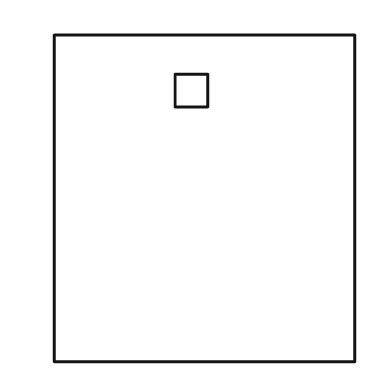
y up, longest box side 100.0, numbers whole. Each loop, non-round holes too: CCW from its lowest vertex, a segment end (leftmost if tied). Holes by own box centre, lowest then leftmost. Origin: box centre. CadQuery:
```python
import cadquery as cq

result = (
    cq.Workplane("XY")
    .moveTo(-46.0, -50.0)
    .lineTo(46.0, -50.0)
    .lineTo(46.0, 50.0)
    .lineTo(-46.0, 50.0)
    .close()
    .moveTo(-9.0, 28.0)
    .lineTo(1.0, 28.0)
    .lineTo(1.0, 38.0)
    .lineTo(-9.0, 38.0)
    .close()
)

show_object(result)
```